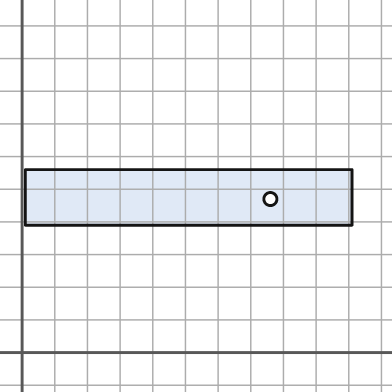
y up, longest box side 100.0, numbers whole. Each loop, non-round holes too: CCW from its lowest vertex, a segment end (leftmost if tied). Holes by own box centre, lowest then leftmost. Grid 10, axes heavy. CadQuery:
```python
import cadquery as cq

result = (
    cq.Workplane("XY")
    .moveTo(1.0, 39.0)
    .lineTo(101.0, 39.0)
    .lineTo(101.0, 56.0)
    .lineTo(1.0, 56.0)
    .close()
    .moveTo(76.0, 47.0)
    .circle(2.0)
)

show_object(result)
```